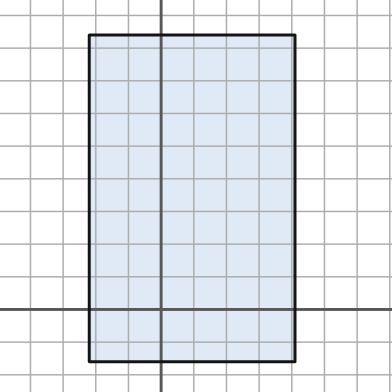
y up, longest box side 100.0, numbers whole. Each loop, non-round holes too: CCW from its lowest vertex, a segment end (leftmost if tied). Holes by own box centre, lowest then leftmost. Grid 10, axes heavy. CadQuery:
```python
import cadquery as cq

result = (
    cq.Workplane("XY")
    .moveTo(-22.0, -16.0)
    .lineTo(41.0, -16.0)
    .lineTo(41.0, 84.0)
    .lineTo(-22.0, 84.0)
    .close()
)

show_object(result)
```